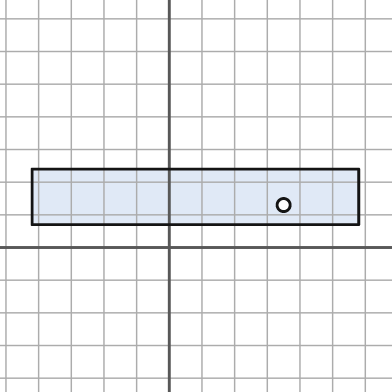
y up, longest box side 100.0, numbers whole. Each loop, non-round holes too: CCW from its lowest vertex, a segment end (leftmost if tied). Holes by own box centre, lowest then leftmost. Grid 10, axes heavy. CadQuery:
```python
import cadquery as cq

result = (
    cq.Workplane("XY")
    .moveTo(-42.0, 7.0)
    .lineTo(58.0, 7.0)
    .lineTo(58.0, 24.0)
    .lineTo(-42.0, 24.0)
    .close()
    .moveTo(35.0, 13.0)
    .circle(2.0)
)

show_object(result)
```